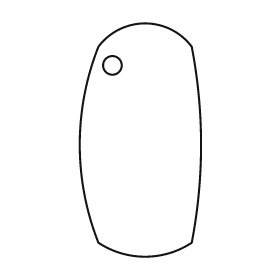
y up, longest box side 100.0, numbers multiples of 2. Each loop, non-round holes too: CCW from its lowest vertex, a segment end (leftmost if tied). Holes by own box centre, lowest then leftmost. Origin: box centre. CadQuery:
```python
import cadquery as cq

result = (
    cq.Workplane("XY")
    .moveTo(-18.0, -44.0)
    .threePointArc((2.0, -50.0), (22.0, -44.0))
    .threePointArc((26.0, -2.0), (22.0, 40.0))
    .threePointArc((2.0, 50.0), (-18.0, 40.0))
    .threePointArc((-26.0, -2.0), (-18.0, -44.0))
    .close()
    .moveTo(-12.0, 32.0)
    .circle(4.0)
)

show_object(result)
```